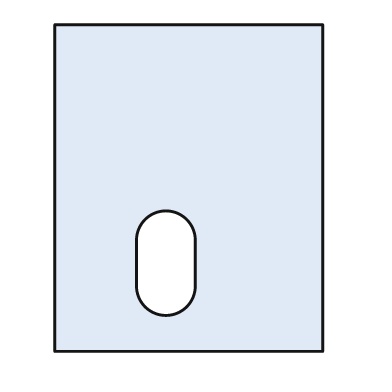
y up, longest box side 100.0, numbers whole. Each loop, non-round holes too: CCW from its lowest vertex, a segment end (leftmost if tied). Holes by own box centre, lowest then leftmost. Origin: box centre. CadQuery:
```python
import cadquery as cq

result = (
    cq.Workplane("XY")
    .moveTo(-41.0, -50.0)
    .lineTo(41.0, -50.0)
    .lineTo(41.0, 50.0)
    .lineTo(-41.0, 50.0)
    .close()
    .moveTo(-16.0, -30.0)
    .threePointArc((-7.0, -39.0), (2.0, -30.0))
    .lineTo(2.0, -16.0)
    .threePointArc((-7.0, -7.0), (-16.0, -16.0))
    .close()
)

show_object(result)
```